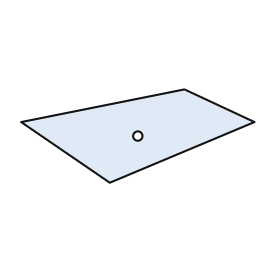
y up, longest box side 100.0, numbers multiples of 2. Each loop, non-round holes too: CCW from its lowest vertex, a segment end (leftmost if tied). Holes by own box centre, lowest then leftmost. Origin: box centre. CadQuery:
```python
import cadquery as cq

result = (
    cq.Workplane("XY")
    .moveTo(-12.0, -20.0)
    .lineTo(50.0, 6.0)
    .lineTo(20.0, 20.0)
    .lineTo(-50.0, 6.0)
    .close()
    .moveTo(0.0, 0.0)
    .circle(2.0)
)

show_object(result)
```